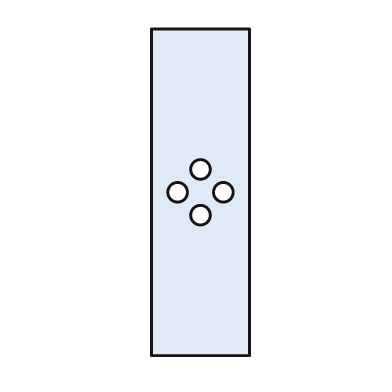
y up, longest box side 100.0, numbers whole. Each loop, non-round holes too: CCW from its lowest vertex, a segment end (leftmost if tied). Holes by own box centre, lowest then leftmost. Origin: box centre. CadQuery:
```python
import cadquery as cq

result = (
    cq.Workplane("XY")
    .moveTo(-15.0, -50.0)
    .lineTo(15.0, -50.0)
    .lineTo(15.0, 50.0)
    .lineTo(-15.0, 50.0)
    .close()
    .moveTo(0.0, -7.0)
    .circle(3.0)
    .moveTo(-7.0, 0.0)
    .circle(3.0)
    .moveTo(7.0, 0.0)
    .circle(3.0)
    .moveTo(0.0, 7.0)
    .circle(3.0)
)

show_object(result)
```